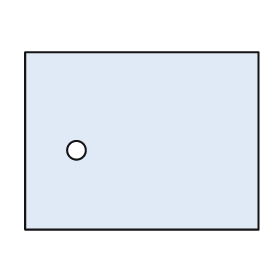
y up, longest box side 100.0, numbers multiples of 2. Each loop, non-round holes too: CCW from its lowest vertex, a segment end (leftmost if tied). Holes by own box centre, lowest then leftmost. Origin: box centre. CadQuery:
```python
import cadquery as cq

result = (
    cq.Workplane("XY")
    .moveTo(-50.0, -38.0)
    .lineTo(50.0, -38.0)
    .lineTo(50.0, 38.0)
    .lineTo(-50.0, 38.0)
    .close()
    .moveTo(-28.0, -4.0)
    .circle(4.0)
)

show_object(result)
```